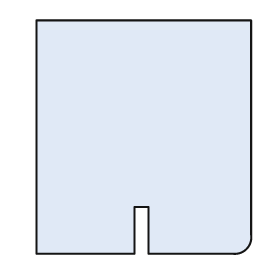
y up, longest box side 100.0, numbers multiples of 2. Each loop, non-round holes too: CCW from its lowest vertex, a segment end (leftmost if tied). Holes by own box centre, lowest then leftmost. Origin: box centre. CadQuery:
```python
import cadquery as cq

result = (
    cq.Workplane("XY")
    .moveTo(-46.0, -50.0)
    .lineTo(-4.0, -50.0)
    .lineTo(-4.0, -30.0)
    .lineTo(2.0, -30.0)
    .lineTo(2.0, -50.0)
    .lineTo(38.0, -50.0)
    .threePointArc((44.0, -48.0), (46.0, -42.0))
    .lineTo(46.0, 50.0)
    .lineTo(-46.0, 50.0)
    .close()
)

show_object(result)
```